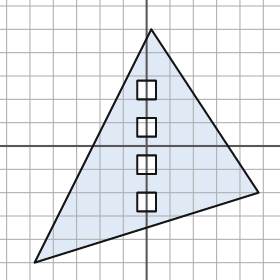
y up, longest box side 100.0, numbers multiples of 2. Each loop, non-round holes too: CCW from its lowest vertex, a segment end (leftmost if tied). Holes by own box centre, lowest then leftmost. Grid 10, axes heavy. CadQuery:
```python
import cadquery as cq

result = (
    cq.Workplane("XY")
    .moveTo(-48.0, -50.0)
    .lineTo(48.0, -20.0)
    .lineTo(2.0, 50.0)
    .close()
    .moveTo(-4.0, -28.0)
    .lineTo(4.0, -28.0)
    .lineTo(4.0, -20.0)
    .lineTo(-4.0, -20.0)
    .close()
    .moveTo(-4.0, -12.0)
    .lineTo(4.0, -12.0)
    .lineTo(4.0, -4.0)
    .lineTo(-4.0, -4.0)
    .close()
    .moveTo(-4.0, 4.0)
    .lineTo(4.0, 4.0)
    .lineTo(4.0, 12.0)
    .lineTo(-4.0, 12.0)
    .close()
    .moveTo(-4.0, 20.0)
    .lineTo(4.0, 20.0)
    .lineTo(4.0, 28.0)
    .lineTo(-4.0, 28.0)
    .close()
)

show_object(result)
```